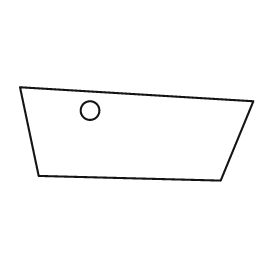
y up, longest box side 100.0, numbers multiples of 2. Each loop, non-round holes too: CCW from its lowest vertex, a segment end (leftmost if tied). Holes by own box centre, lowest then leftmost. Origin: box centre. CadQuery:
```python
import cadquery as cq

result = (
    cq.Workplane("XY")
    .moveTo(36.0, -20.0)
    .lineTo(50.0, 14.0)
    .lineTo(-50.0, 20.0)
    .lineTo(-42.0, -18.0)
    .close()
    .moveTo(-20.0, 10.0)
    .circle(4.0)
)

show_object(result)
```